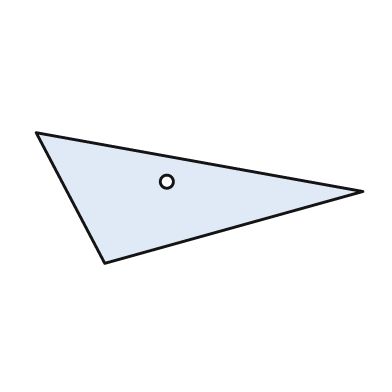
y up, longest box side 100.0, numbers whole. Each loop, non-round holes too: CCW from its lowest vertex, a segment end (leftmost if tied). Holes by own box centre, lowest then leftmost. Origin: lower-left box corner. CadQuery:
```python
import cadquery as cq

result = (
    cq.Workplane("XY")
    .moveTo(21.0, 0.0)
    .lineTo(100.0, 22.0)
    .lineTo(0.0, 40.0)
    .close()
    .moveTo(40.0, 25.0)
    .circle(2.0)
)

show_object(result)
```